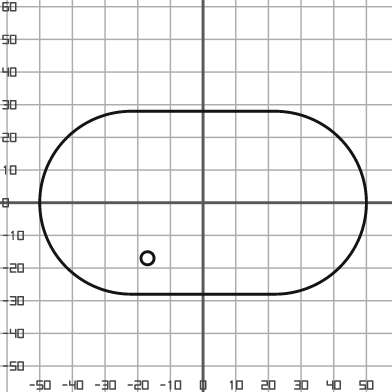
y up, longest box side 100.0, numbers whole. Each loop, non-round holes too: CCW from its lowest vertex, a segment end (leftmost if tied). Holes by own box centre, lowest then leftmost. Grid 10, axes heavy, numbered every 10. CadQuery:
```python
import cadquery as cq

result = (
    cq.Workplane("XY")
    .moveTo(-22.0, -28.0)
    .lineTo(22.0, -28.0)
    .threePointArc((50.0, 0.0), (22.0, 28.0))
    .lineTo(-22.0, 28.0)
    .threePointArc((-50.0, 0.0), (-22.0, -28.0))
    .close()
    .moveTo(-17.0, -17.0)
    .circle(2.0)
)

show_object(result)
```